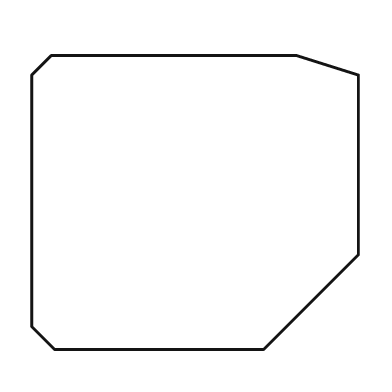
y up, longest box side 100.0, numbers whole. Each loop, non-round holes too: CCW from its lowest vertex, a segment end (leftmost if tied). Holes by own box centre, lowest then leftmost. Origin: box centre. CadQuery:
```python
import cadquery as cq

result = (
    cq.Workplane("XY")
    .moveTo(-43.0, -45.0)
    .lineTo(21.0, -45.0)
    .lineTo(50.0, -16.0)
    .lineTo(50.0, 39.0)
    .lineTo(31.0, 45.0)
    .lineTo(-44.0, 45.0)
    .lineTo(-50.0, 39.0)
    .lineTo(-50.0, -38.0)
    .close()
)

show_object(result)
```